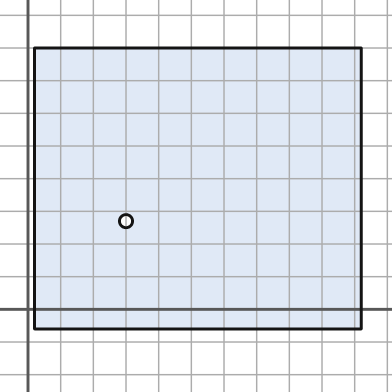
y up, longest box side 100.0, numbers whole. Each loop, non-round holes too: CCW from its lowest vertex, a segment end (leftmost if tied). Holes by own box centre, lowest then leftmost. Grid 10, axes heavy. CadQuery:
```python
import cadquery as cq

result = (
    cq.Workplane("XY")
    .moveTo(2.0, -6.0)
    .lineTo(102.0, -6.0)
    .lineTo(102.0, 80.0)
    .lineTo(2.0, 80.0)
    .close()
    .moveTo(30.0, 27.0)
    .circle(2.0)
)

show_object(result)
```